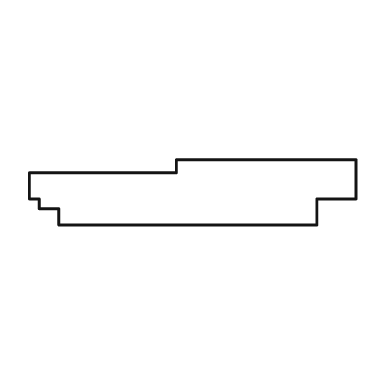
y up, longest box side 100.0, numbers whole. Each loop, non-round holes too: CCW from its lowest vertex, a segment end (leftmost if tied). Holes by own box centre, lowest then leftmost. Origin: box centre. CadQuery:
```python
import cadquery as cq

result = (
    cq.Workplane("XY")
    .moveTo(-41.0, -10.0)
    .lineTo(38.0, -10.0)
    .lineTo(38.0, -2.0)
    .lineTo(50.0, -2.0)
    .lineTo(50.0, 10.0)
    .lineTo(-5.0, 10.0)
    .lineTo(-5.0, 6.0)
    .lineTo(-50.0, 6.0)
    .lineTo(-50.0, -2.0)
    .lineTo(-47.0, -2.0)
    .lineTo(-47.0, -5.0)
    .lineTo(-41.0, -5.0)
    .close()
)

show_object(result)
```